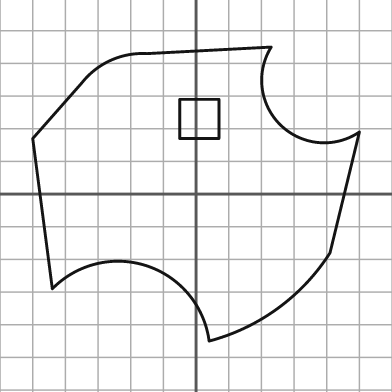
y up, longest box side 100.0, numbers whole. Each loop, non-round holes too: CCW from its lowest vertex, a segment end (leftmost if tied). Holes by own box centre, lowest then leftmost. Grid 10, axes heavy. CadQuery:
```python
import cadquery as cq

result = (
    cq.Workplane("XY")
    .moveTo(4.0, -45.0)
    .threePointArc((25.0, -35.0), (41.0, -18.0))
    .lineTo(50.0, 19.0)
    .threePointArc((26.0, 21.0), (23.0, 45.0))
    .lineTo(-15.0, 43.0)
    .threePointArc((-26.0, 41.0), (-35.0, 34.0))
    .lineTo(-50.0, 17.0)
    .lineTo(-44.0, -29.0)
    .threePointArc((-15.0, -22.0), (4.0, -45.0))
    .close()
    .moveTo(-5.0, 17.0)
    .lineTo(7.0, 17.0)
    .lineTo(7.0, 29.0)
    .lineTo(-5.0, 29.0)
    .close()
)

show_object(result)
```